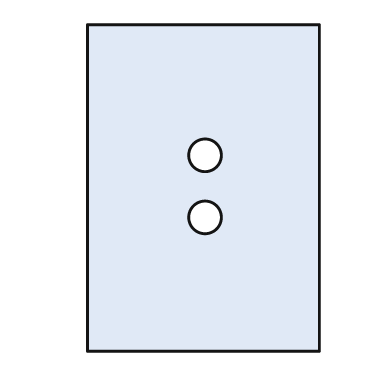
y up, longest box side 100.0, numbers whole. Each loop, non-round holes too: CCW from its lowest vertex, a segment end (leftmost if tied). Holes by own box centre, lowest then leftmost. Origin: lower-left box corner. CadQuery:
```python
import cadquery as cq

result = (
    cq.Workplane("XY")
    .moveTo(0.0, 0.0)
    .lineTo(71.0, 0.0)
    .lineTo(71.0, 100.0)
    .lineTo(0.0, 100.0)
    .close()
    .moveTo(36.0, 41.0)
    .circle(5.0)
    .moveTo(36.0, 60.0)
    .circle(5.0)
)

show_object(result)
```